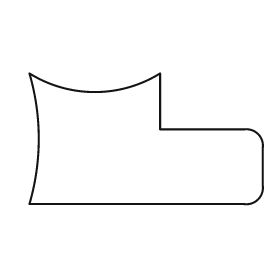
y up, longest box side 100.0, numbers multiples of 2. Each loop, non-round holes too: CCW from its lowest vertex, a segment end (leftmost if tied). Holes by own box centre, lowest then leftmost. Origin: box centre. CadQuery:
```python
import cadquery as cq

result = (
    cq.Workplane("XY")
    .moveTo(-50.0, -28.0)
    .lineTo(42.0, -28.0)
    .threePointArc((48.0, -26.0), (50.0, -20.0))
    .lineTo(50.0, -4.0)
    .threePointArc((48.0, 2.0), (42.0, 4.0))
    .lineTo(6.0, 4.0)
    .lineTo(6.0, 28.0)
    .threePointArc((-22.0, 20.0), (-50.0, 28.0))
    .threePointArc((-46.0, 0.0), (-50.0, -28.0))
    .close()
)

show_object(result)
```